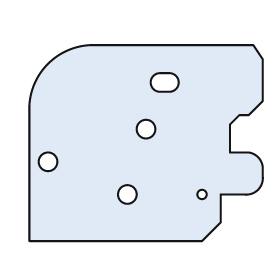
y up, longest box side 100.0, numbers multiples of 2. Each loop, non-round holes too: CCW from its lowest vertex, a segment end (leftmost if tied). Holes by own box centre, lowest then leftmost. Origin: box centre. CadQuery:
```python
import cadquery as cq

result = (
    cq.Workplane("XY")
    .moveTo(-50.0, -42.0)
    .lineTo(24.0, -42.0)
    .lineTo(32.0, -34.0)
    .lineTo(32.0, -22.0)
    .lineTo(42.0, -22.0)
    .threePointArc((48.0, -20.0), (50.0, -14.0))
    .lineTo(50.0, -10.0)
    .threePointArc((48.0, -6.0), (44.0, -4.0))
    .lineTo(36.0, -4.0)
    .lineTo(36.0, 8.0)
    .lineTo(40.0, 12.0)
    .lineTo(44.0, 12.0)
    .lineTo(50.0, 18.0)
    .lineTo(50.0, 36.0)
    .lineTo(46.0, 42.0)
    .lineTo(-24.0, 42.0)
    .threePointArc((-42.0, 34.0), (-50.0, 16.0))
    .close()
    .moveTo(-8.0, -22.0)
    .circle(4.0)
    .moveTo(24.0, -22.0)
    .circle(2.0)
    .moveTo(-42.0, -8.0)
    .circle(4.0)
    .moveTo(0.0, 6.0)
    .circle(4.0)
    .moveTo(6.0, 22.0)
    .lineTo(10.0, 22.0)
    .threePointArc((14.0, 26.0), (10.0, 30.0))
    .lineTo(6.0, 30.0)
    .threePointArc((2.0, 26.0), (6.0, 22.0))
    .close()
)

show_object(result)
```